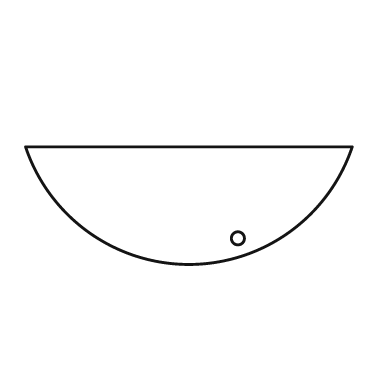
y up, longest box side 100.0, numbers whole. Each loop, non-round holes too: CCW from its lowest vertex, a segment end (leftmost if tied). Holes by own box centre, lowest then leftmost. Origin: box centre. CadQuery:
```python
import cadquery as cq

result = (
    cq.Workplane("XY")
    .moveTo(-50.0, 18.0)
    .threePointArc((0.0, -18.0), (50.0, 18.0))
    .close()
    .moveTo(15.0, -10.0)
    .circle(2.0)
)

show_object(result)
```